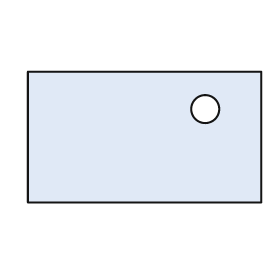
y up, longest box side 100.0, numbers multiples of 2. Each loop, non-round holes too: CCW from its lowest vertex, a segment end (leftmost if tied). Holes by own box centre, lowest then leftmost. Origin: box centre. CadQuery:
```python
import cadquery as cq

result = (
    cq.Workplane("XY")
    .moveTo(-50.0, -28.0)
    .lineTo(50.0, -28.0)
    .lineTo(50.0, 28.0)
    .lineTo(-50.0, 28.0)
    .close()
    .moveTo(26.0, 12.0)
    .circle(6.0)
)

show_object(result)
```